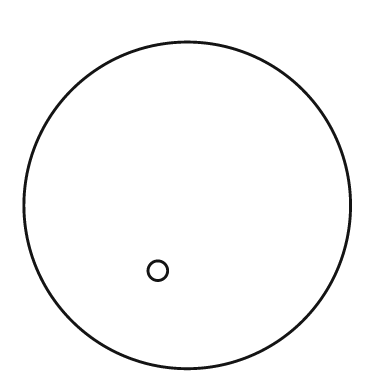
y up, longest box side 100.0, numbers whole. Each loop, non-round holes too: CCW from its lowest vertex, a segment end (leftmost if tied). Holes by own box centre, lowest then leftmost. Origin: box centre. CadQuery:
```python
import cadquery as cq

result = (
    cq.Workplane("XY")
    .moveTo(0.0, 0.0)
    .circle(50.0)
    .moveTo(-9.0, -20.0)
    .circle(3.0)
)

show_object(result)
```